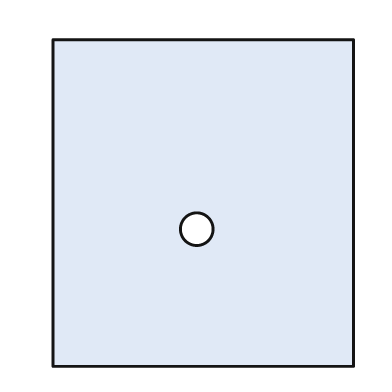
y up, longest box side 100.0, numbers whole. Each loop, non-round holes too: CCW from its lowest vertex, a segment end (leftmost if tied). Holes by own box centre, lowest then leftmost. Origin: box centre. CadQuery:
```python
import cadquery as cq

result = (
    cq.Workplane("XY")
    .moveTo(-46.0, -50.0)
    .lineTo(46.0, -50.0)
    .lineTo(46.0, 50.0)
    .lineTo(-46.0, 50.0)
    .close()
    .moveTo(-2.0, -8.0)
    .circle(5.0)
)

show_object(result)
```